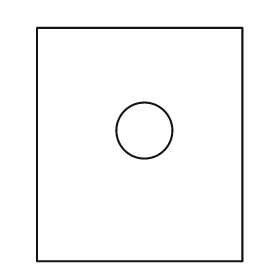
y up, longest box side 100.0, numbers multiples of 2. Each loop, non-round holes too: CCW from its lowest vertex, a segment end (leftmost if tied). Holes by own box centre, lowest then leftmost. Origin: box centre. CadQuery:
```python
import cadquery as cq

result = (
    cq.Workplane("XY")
    .moveTo(-44.0, -50.0)
    .lineTo(44.0, -50.0)
    .lineTo(44.0, 50.0)
    .lineTo(-44.0, 50.0)
    .close()
    .moveTo(2.0, 6.0)
    .circle(12.0)
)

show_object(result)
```